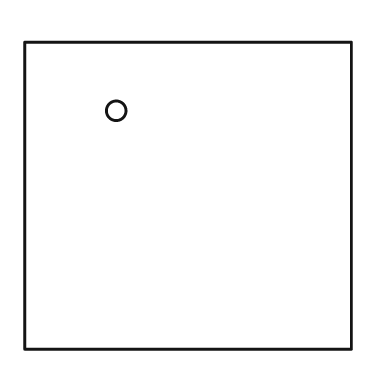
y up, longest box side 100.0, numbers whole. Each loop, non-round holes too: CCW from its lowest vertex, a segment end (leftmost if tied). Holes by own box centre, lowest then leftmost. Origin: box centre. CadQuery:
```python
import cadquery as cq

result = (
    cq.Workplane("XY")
    .moveTo(-50.0, -47.0)
    .lineTo(50.0, -47.0)
    .lineTo(50.0, 47.0)
    .lineTo(-50.0, 47.0)
    .close()
    .moveTo(-22.0, 26.0)
    .circle(3.0)
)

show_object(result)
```